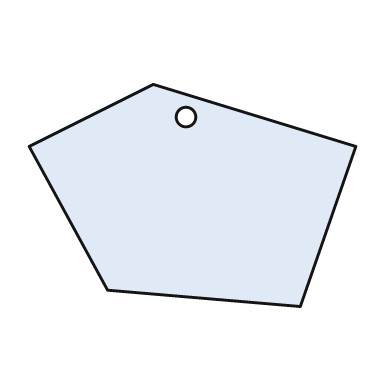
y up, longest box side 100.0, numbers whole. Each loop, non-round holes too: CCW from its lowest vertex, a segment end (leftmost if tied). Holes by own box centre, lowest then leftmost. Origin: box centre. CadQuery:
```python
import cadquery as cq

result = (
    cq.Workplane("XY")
    .moveTo(33.0, -34.0)
    .lineTo(50.0, 15.0)
    .lineTo(-12.0, 34.0)
    .lineTo(-50.0, 15.0)
    .lineTo(-26.0, -29.0)
    .close()
    .moveTo(-2.0, 24.0)
    .circle(3.0)
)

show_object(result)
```